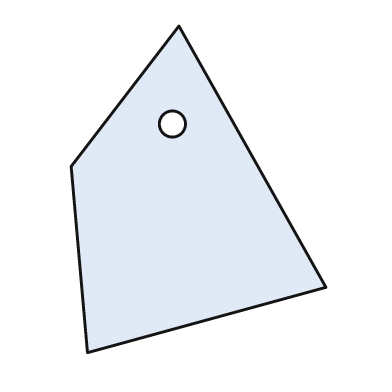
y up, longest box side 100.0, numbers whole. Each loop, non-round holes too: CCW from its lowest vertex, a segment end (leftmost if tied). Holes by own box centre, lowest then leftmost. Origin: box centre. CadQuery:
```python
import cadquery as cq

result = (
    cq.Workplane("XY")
    .moveTo(-34.0, -50.0)
    .lineTo(39.0, -30.0)
    .lineTo(-6.0, 50.0)
    .lineTo(-39.0, 7.0)
    .close()
    .moveTo(-8.0, 20.0)
    .circle(4.0)
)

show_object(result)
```